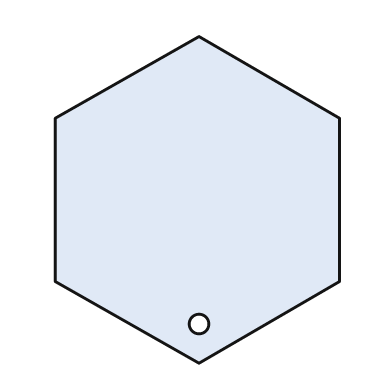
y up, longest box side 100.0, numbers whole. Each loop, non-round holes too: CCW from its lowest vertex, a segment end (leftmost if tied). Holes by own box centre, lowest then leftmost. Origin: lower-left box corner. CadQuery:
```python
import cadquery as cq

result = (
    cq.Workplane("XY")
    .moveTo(44.0, 0.0)
    .lineTo(87.0, 25.0)
    .lineTo(87.0, 75.0)
    .lineTo(44.0, 100.0)
    .lineTo(0.0, 75.0)
    .lineTo(0.0, 25.0)
    .close()
    .moveTo(44.0, 12.0)
    .circle(3.0)
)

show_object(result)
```